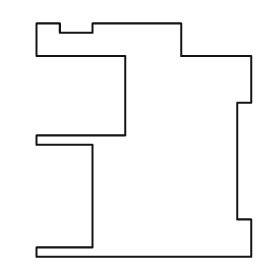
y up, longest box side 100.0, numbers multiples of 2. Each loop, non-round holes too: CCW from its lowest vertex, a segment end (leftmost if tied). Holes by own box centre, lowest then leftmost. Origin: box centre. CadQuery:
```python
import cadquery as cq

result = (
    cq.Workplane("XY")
    .moveTo(-46.0, -50.0)
    .lineTo(46.0, -50.0)
    .lineTo(46.0, -34.0)
    .lineTo(40.0, -34.0)
    .lineTo(40.0, 16.0)
    .lineTo(46.0, 16.0)
    .lineTo(46.0, 36.0)
    .lineTo(16.0, 36.0)
    .lineTo(16.0, 50.0)
    .lineTo(-22.0, 50.0)
    .lineTo(-22.0, 46.0)
    .lineTo(-36.0, 46.0)
    .lineTo(-36.0, 50.0)
    .lineTo(-46.0, 50.0)
    .lineTo(-46.0, 36.0)
    .lineTo(-8.0, 36.0)
    .lineTo(-8.0, 2.0)
    .lineTo(-46.0, 2.0)
    .lineTo(-46.0, -2.0)
    .lineTo(-22.0, -2.0)
    .lineTo(-22.0, -46.0)
    .lineTo(-46.0, -46.0)
    .close()
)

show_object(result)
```